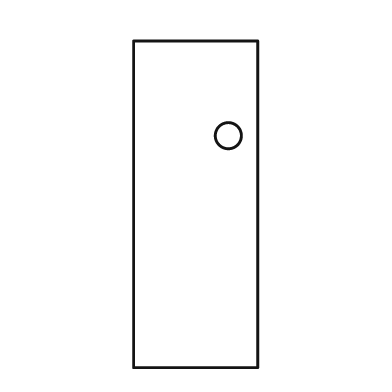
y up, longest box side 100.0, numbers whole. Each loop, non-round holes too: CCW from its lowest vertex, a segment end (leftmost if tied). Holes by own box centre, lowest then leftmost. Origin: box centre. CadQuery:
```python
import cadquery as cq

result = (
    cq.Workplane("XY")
    .moveTo(-19.0, -50.0)
    .lineTo(19.0, -50.0)
    .lineTo(19.0, 50.0)
    .lineTo(-19.0, 50.0)
    .close()
    .moveTo(10.0, 21.0)
    .circle(4.0)
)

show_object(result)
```